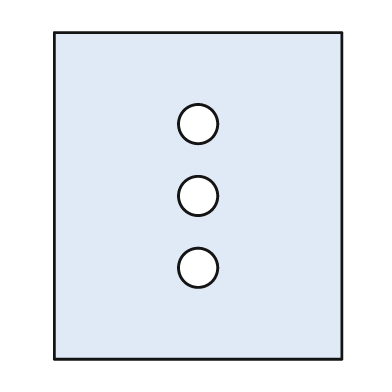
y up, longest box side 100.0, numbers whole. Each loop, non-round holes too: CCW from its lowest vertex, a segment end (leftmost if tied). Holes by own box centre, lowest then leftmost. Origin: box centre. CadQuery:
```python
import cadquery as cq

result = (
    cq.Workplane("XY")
    .moveTo(-44.0, -50.0)
    .lineTo(44.0, -50.0)
    .lineTo(44.0, 50.0)
    .lineTo(-44.0, 50.0)
    .close()
    .moveTo(0.0, -22.0)
    .circle(6.0)
    .moveTo(0.0, 0.0)
    .circle(6.0)
    .moveTo(0.0, 22.0)
    .circle(6.0)
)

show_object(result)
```